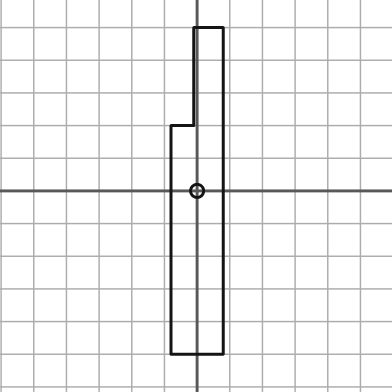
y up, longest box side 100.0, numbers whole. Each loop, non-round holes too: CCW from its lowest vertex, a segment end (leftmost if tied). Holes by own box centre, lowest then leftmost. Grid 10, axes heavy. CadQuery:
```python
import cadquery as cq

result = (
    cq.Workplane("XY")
    .moveTo(-8.0, -50.0)
    .lineTo(8.0, -50.0)
    .lineTo(8.0, 50.0)
    .lineTo(-1.0, 50.0)
    .lineTo(-1.0, 20.0)
    .lineTo(-8.0, 20.0)
    .close()
    .moveTo(0.0, 0.0)
    .circle(2.0)
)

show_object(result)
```